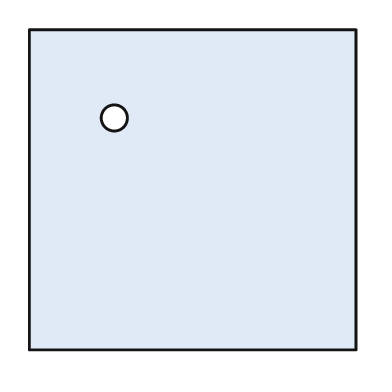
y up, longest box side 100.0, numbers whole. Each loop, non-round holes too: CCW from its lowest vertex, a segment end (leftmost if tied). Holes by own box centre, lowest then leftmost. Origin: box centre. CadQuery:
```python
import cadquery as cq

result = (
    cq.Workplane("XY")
    .moveTo(-50.0, -49.0)
    .lineTo(50.0, -49.0)
    .lineTo(50.0, 49.0)
    .lineTo(-50.0, 49.0)
    .close()
    .moveTo(-24.0, 22.0)
    .circle(4.0)
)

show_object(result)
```